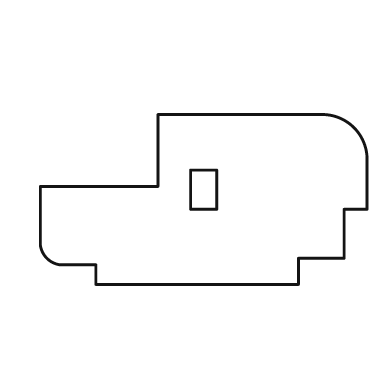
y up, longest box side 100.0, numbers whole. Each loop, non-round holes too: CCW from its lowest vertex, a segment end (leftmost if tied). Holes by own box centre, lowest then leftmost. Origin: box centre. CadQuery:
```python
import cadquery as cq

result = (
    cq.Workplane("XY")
    .moveTo(-33.0, -26.0)
    .lineTo(29.0, -26.0)
    .lineTo(29.0, -18.0)
    .lineTo(43.0, -18.0)
    .lineTo(43.0, -3.0)
    .lineTo(50.0, -3.0)
    .lineTo(50.0, 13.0)
    .threePointArc((46.0, 22.0), (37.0, 26.0))
    .lineTo(-14.0, 26.0)
    .lineTo(-14.0, 4.0)
    .lineTo(-50.0, 4.0)
    .lineTo(-50.0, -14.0)
    .threePointArc((-48.0, -18.0), (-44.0, -20.0))
    .lineTo(-33.0, -20.0)
    .close()
    .moveTo(-4.0, -3.0)
    .lineTo(4.0, -3.0)
    .lineTo(4.0, 9.0)
    .lineTo(-4.0, 9.0)
    .close()
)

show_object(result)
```